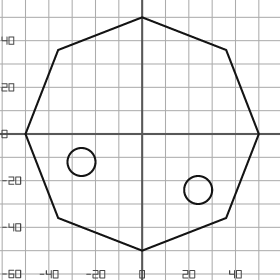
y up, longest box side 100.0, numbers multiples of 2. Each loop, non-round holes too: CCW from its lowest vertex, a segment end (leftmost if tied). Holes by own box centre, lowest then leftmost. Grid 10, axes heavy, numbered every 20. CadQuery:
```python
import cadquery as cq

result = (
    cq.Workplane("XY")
    .moveTo(0.0, -50.0)
    .lineTo(36.0, -36.0)
    .lineTo(50.0, 0.0)
    .lineTo(36.0, 36.0)
    .lineTo(0.0, 50.0)
    .lineTo(-36.0, 36.0)
    .lineTo(-50.0, 0.0)
    .lineTo(-36.0, -36.0)
    .close()
    .moveTo(24.0, -24.0)
    .circle(6.0)
    .moveTo(-26.0, -12.0)
    .circle(6.0)
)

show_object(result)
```